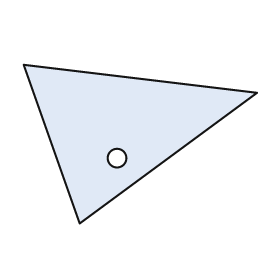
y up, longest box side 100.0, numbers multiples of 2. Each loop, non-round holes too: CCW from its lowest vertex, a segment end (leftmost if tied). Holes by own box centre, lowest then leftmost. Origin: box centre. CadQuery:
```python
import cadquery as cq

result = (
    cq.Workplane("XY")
    .moveTo(-26.0, -34.0)
    .lineTo(50.0, 22.0)
    .lineTo(-50.0, 34.0)
    .close()
    .moveTo(-10.0, -6.0)
    .circle(4.0)
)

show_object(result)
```